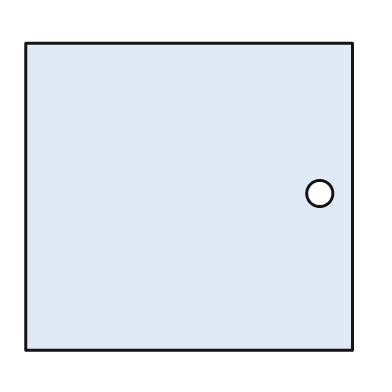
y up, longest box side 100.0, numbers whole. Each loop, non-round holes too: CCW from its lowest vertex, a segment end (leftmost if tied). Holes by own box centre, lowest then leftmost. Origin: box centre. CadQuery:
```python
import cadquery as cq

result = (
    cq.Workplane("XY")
    .moveTo(-50.0, -47.0)
    .lineTo(50.0, -47.0)
    .lineTo(50.0, 47.0)
    .lineTo(-50.0, 47.0)
    .close()
    .moveTo(40.0, 1.0)
    .circle(4.0)
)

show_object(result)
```